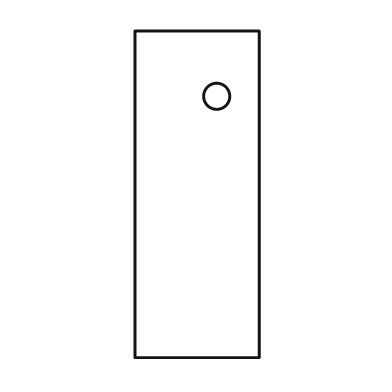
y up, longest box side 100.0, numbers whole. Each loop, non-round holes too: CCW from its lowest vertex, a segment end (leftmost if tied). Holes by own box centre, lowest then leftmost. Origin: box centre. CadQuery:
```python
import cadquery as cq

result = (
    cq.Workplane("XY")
    .moveTo(-19.0, -50.0)
    .lineTo(19.0, -50.0)
    .lineTo(19.0, 50.0)
    .lineTo(-19.0, 50.0)
    .close()
    .moveTo(6.0, 30.0)
    .circle(4.0)
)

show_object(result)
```